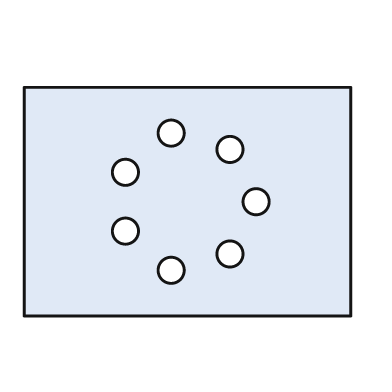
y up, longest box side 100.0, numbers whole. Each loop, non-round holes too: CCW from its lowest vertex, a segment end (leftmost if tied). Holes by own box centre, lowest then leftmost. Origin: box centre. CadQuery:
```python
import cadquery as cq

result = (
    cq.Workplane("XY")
    .moveTo(-50.0, -35.0)
    .lineTo(50.0, -35.0)
    .lineTo(50.0, 35.0)
    .lineTo(-50.0, 35.0)
    .close()
    .moveTo(-5.0, -21.0)
    .circle(4.0)
    .moveTo(13.0, -16.0)
    .circle(4.0)
    .moveTo(-19.0, -9.0)
    .circle(4.0)
    .moveTo(21.0, 0.0)
    .circle(4.0)
    .moveTo(-19.0, 9.0)
    .circle(4.0)
    .moveTo(13.0, 16.0)
    .circle(4.0)
    .moveTo(-5.0, 21.0)
    .circle(4.0)
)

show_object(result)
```